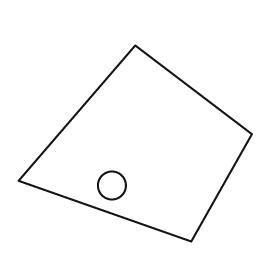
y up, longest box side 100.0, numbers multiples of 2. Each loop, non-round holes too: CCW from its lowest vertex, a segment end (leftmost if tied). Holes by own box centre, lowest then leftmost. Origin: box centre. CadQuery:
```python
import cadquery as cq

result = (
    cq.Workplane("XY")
    .moveTo(24.0, -42.0)
    .lineTo(50.0, 4.0)
    .lineTo(0.0, 42.0)
    .lineTo(-50.0, -16.0)
    .close()
    .moveTo(-10.0, -18.0)
    .circle(6.0)
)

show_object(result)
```